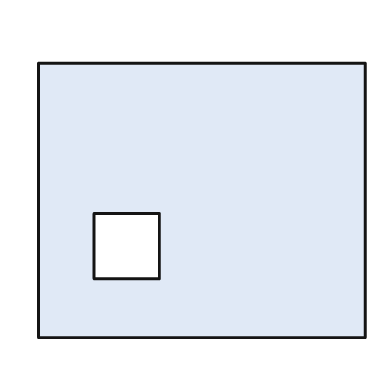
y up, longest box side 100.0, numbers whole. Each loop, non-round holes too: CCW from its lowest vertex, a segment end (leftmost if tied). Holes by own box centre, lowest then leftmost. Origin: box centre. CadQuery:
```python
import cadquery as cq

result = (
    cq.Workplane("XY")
    .moveTo(-50.0, -42.0)
    .lineTo(50.0, -42.0)
    .lineTo(50.0, 42.0)
    .lineTo(-50.0, 42.0)
    .close()
    .moveTo(-33.0, -24.0)
    .lineTo(-13.0, -24.0)
    .lineTo(-13.0, -4.0)
    .lineTo(-33.0, -4.0)
    .close()
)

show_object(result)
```